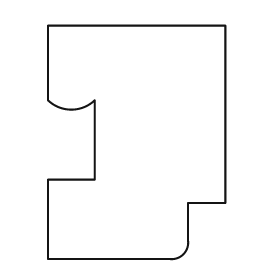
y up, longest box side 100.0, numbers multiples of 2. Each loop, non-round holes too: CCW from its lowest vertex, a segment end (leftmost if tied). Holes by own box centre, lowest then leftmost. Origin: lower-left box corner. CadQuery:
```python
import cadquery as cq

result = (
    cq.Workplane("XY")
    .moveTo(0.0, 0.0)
    .lineTo(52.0, 0.0)
    .threePointArc((58.0, 2.0), (60.0, 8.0))
    .lineTo(60.0, 24.0)
    .lineTo(76.0, 24.0)
    .lineTo(76.0, 100.0)
    .lineTo(0.0, 100.0)
    .lineTo(0.0, 68.0)
    .threePointArc((10.0, 64.0), (20.0, 68.0))
    .lineTo(20.0, 34.0)
    .lineTo(0.0, 34.0)
    .close()
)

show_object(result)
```